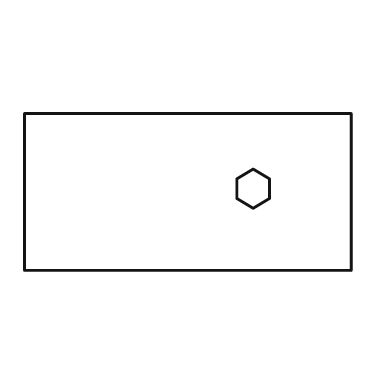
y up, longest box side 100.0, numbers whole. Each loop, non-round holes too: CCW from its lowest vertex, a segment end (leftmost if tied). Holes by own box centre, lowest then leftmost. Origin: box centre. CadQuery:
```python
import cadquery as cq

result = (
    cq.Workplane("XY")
    .moveTo(-50.0, -24.0)
    .lineTo(50.0, -24.0)
    .lineTo(50.0, 24.0)
    .lineTo(-50.0, 24.0)
    .close()
    .moveTo(20.0, -5.0)
    .lineTo(25.0, -2.0)
    .lineTo(25.0, 4.0)
    .lineTo(20.0, 7.0)
    .lineTo(15.0, 4.0)
    .lineTo(15.0, -2.0)
    .close()
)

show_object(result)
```